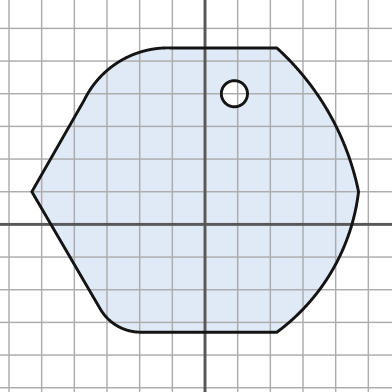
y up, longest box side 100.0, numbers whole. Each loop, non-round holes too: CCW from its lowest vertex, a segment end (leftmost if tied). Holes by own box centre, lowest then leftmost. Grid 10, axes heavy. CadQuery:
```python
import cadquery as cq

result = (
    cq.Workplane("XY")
    .moveTo(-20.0, -33.0)
    .lineTo(22.0, -33.0)
    .threePointArc((39.0, -14.0), (47.0, 10.0))
    .threePointArc((38.0, 34.0), (22.0, 54.0))
    .lineTo(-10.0, 54.0)
    .threePointArc((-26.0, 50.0), (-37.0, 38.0))
    .lineTo(-53.0, 10.0)
    .lineTo(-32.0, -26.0)
    .threePointArc((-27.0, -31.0), (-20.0, -33.0))
    .close()
    .moveTo(9.0, 40.0)
    .circle(4.0)
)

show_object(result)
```